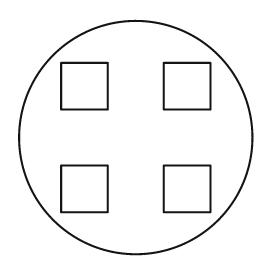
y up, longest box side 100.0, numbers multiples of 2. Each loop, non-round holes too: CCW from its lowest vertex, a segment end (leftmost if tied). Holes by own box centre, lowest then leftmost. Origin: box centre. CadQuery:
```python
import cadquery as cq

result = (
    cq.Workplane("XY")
    .moveTo(0.0, 0.0)
    .circle(50.0)
    .moveTo(-32.0, -32.0)
    .lineTo(-12.0, -32.0)
    .lineTo(-12.0, -12.0)
    .lineTo(-32.0, -12.0)
    .close()
    .moveTo(12.0, -32.0)
    .lineTo(32.0, -32.0)
    .lineTo(32.0, -12.0)
    .lineTo(12.0, -12.0)
    .close()
    .moveTo(-32.0, 12.0)
    .lineTo(-12.0, 12.0)
    .lineTo(-12.0, 32.0)
    .lineTo(-32.0, 32.0)
    .close()
    .moveTo(12.0, 12.0)
    .lineTo(32.0, 12.0)
    .lineTo(32.0, 32.0)
    .lineTo(12.0, 32.0)
    .close()
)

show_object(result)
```